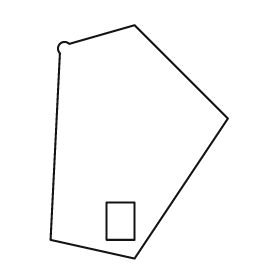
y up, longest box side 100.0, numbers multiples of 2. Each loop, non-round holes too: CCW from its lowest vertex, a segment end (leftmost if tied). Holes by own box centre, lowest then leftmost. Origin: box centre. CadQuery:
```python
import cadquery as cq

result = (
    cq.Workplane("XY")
    .moveTo(-2.0, -50.0)
    .lineTo(38.0, 10.0)
    .lineTo(-2.0, 50.0)
    .lineTo(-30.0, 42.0)
    .threePointArc((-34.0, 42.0), (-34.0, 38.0))
    .lineTo(-38.0, -42.0)
    .close()
    .moveTo(-14.0, -42.0)
    .lineTo(-2.0, -42.0)
    .lineTo(-2.0, -26.0)
    .lineTo(-14.0, -26.0)
    .close()
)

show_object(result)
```